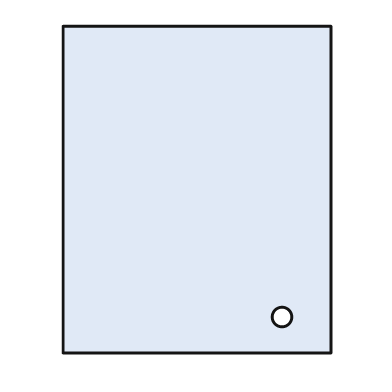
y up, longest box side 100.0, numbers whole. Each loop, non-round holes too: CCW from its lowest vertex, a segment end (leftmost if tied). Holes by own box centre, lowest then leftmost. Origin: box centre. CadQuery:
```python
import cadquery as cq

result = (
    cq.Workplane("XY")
    .moveTo(-41.0, -50.0)
    .lineTo(41.0, -50.0)
    .lineTo(41.0, 50.0)
    .lineTo(-41.0, 50.0)
    .close()
    .moveTo(26.0, -39.0)
    .circle(3.0)
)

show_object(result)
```